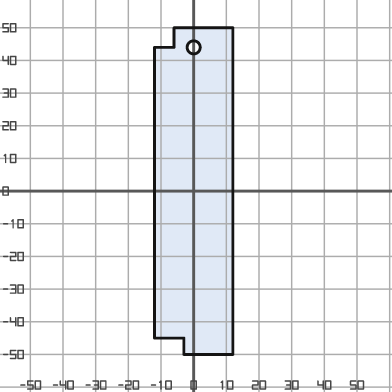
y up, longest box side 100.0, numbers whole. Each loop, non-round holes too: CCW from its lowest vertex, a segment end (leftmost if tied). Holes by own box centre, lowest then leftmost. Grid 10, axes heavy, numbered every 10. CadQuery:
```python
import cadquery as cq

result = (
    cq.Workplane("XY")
    .moveTo(-3.0, -50.0)
    .lineTo(12.0, -50.0)
    .lineTo(12.0, 50.0)
    .lineTo(-6.0, 50.0)
    .lineTo(-6.0, 44.0)
    .lineTo(-12.0, 44.0)
    .lineTo(-12.0, -45.0)
    .lineTo(-3.0, -45.0)
    .close()
    .moveTo(0.0, 44.0)
    .circle(2.0)
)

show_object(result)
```